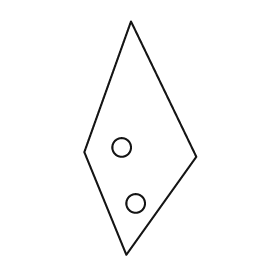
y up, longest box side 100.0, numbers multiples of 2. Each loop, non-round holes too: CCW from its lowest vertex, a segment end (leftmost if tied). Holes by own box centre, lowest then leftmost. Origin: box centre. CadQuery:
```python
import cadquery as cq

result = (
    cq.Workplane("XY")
    .moveTo(-6.0, -50.0)
    .lineTo(24.0, -8.0)
    .lineTo(-4.0, 50.0)
    .lineTo(-24.0, -6.0)
    .close()
    .moveTo(-2.0, -28.0)
    .circle(4.0)
    .moveTo(-8.0, -4.0)
    .circle(4.0)
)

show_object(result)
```